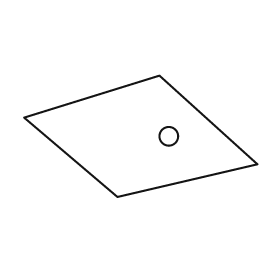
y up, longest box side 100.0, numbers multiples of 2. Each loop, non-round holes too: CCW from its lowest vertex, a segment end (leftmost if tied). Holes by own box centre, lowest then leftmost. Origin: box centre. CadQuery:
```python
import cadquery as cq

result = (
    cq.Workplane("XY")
    .moveTo(-10.0, -26.0)
    .lineTo(50.0, -12.0)
    .lineTo(8.0, 26.0)
    .lineTo(-50.0, 8.0)
    .close()
    .moveTo(12.0, 0.0)
    .circle(4.0)
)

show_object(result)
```